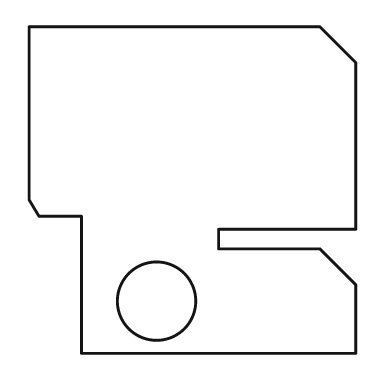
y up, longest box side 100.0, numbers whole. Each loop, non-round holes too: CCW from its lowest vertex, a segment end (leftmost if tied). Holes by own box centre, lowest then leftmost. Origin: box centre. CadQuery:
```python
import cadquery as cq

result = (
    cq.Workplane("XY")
    .moveTo(-34.0, -50.0)
    .lineTo(50.0, -50.0)
    .lineTo(50.0, -29.0)
    .lineTo(39.0, -18.0)
    .lineTo(8.0, -18.0)
    .lineTo(8.0, -12.0)
    .lineTo(50.0, -12.0)
    .lineTo(50.0, 39.0)
    .lineTo(39.0, 50.0)
    .lineTo(-50.0, 50.0)
    .lineTo(-50.0, -3.0)
    .lineTo(-47.0, -8.0)
    .lineTo(-34.0, -8.0)
    .close()
    .moveTo(-11.0, -34.0)
    .circle(12.0)
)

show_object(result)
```